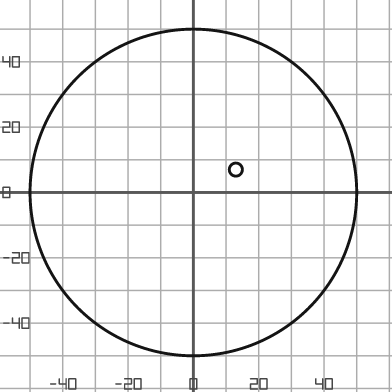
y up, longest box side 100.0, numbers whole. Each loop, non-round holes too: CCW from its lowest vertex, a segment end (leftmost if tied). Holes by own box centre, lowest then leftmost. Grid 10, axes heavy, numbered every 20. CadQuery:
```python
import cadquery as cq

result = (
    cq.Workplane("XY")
    .moveTo(0.0, 0.0)
    .circle(50.0)
    .moveTo(13.0, 7.0)
    .circle(2.0)
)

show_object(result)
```